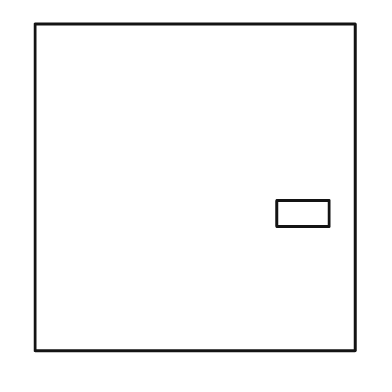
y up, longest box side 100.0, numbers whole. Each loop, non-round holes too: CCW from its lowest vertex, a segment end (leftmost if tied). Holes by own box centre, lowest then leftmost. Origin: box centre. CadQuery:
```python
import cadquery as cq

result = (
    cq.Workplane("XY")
    .moveTo(-49.0, -50.0)
    .lineTo(49.0, -50.0)
    .lineTo(49.0, 50.0)
    .lineTo(-49.0, 50.0)
    .close()
    .moveTo(25.0, -12.0)
    .lineTo(41.0, -12.0)
    .lineTo(41.0, -4.0)
    .lineTo(25.0, -4.0)
    .close()
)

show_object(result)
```